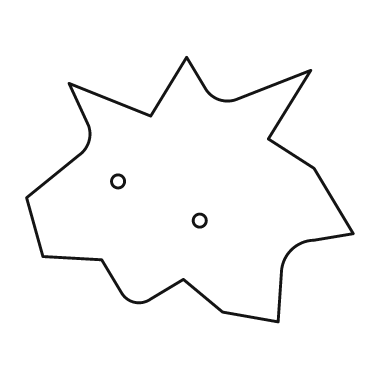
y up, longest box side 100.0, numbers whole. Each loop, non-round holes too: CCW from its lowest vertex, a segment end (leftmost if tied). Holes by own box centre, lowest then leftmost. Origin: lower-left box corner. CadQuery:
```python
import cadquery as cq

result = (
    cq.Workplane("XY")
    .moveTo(77.0, 0.0)
    .lineTo(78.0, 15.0)
    .threePointArc((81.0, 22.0), (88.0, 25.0))
    .lineTo(100.0, 27.0)
    .lineTo(88.0, 47.0)
    .lineTo(74.0, 56.0)
    .lineTo(87.0, 77.0)
    .lineTo(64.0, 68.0)
    .threePointArc((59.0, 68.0), (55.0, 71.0))
    .lineTo(49.0, 81.0)
    .lineTo(38.0, 63.0)
    .lineTo(13.0, 73.0)
    .lineTo(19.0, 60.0)
    .threePointArc((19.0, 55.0), (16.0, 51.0))
    .lineTo(0.0, 38.0)
    .lineTo(5.0, 20.0)
    .lineTo(23.0, 19.0)
    .lineTo(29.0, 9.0)
    .threePointArc((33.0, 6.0), (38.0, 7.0))
    .lineTo(48.0, 13.0)
    .lineTo(60.0, 3.0)
    .close()
    .moveTo(53.0, 31.0)
    .circle(2.0)
    .moveTo(28.0, 43.0)
    .circle(2.0)
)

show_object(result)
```